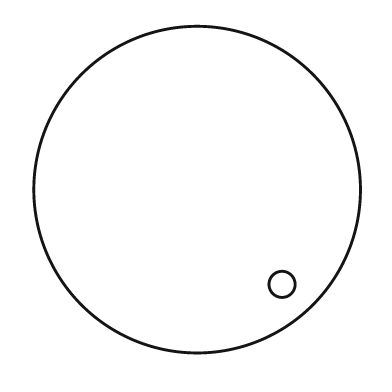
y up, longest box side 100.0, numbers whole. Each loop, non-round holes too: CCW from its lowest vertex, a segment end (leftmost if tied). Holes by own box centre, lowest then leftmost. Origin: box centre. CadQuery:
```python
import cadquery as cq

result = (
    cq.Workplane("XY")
    .moveTo(0.0, 0.0)
    .circle(50.0)
    .moveTo(26.0, -29.0)
    .circle(4.0)
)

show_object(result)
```